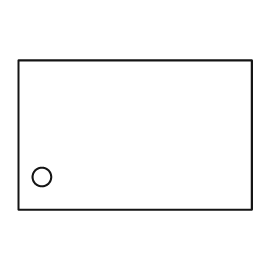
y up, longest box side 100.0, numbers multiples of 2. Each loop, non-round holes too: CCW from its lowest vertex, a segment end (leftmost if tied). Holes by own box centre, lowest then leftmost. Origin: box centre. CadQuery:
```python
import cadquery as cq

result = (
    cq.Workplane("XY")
    .moveTo(-50.0, -32.0)
    .lineTo(50.0, -32.0)
    .lineTo(50.0, 32.0)
    .lineTo(-50.0, 32.0)
    .close()
    .moveTo(-40.0, -18.0)
    .circle(4.0)
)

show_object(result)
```